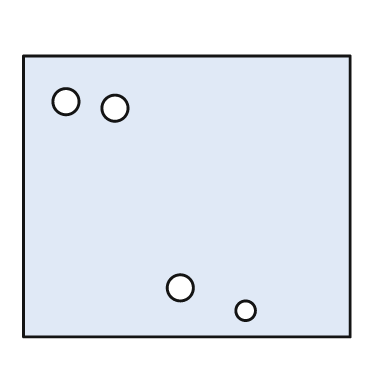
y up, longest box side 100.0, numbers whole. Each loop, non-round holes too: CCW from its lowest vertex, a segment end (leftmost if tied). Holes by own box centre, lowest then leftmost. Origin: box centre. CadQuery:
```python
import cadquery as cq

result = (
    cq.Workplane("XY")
    .moveTo(-50.0, -43.0)
    .lineTo(50.0, -43.0)
    .lineTo(50.0, 43.0)
    .lineTo(-50.0, 43.0)
    .close()
    .moveTo(18.0, -35.0)
    .circle(3.0)
    .moveTo(-2.0, -28.0)
    .circle(4.0)
    .moveTo(-22.0, 27.0)
    .circle(4.0)
    .moveTo(-37.0, 29.0)
    .circle(4.0)
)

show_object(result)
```